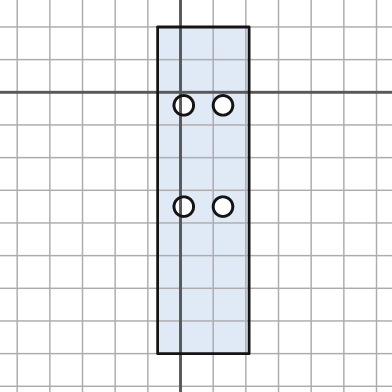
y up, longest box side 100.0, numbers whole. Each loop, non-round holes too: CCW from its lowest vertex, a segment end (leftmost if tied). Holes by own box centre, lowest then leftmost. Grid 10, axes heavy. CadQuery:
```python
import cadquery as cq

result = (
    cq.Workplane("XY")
    .moveTo(-7.0, -80.0)
    .lineTo(21.0, -80.0)
    .lineTo(21.0, 20.0)
    .lineTo(-7.0, 20.0)
    .close()
    .moveTo(1.0, -35.0)
    .circle(3.0)
    .moveTo(13.0, -35.0)
    .circle(3.0)
    .moveTo(1.0, -4.0)
    .circle(3.0)
    .moveTo(13.0, -4.0)
    .circle(3.0)
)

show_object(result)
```